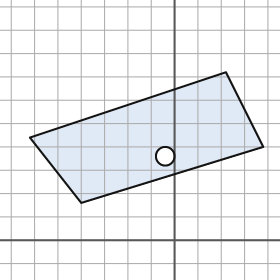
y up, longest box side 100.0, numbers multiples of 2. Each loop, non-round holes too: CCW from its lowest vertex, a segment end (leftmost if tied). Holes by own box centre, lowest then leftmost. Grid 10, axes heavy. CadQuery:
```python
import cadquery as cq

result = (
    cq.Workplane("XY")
    .moveTo(-40.0, 16.0)
    .lineTo(38.0, 40.0)
    .lineTo(22.0, 72.0)
    .lineTo(-62.0, 44.0)
    .close()
    .moveTo(-4.0, 36.0)
    .circle(4.0)
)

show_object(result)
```